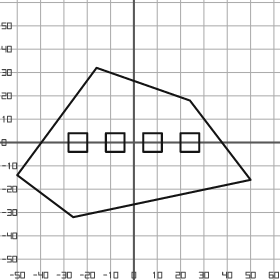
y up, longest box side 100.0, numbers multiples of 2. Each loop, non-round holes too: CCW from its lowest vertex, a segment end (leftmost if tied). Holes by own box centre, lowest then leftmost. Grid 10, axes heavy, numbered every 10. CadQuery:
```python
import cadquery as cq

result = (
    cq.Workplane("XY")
    .moveTo(-26.0, -32.0)
    .lineTo(50.0, -16.0)
    .lineTo(24.0, 18.0)
    .lineTo(-16.0, 32.0)
    .lineTo(-50.0, -14.0)
    .close()
    .moveTo(-28.0, -4.0)
    .lineTo(-20.0, -4.0)
    .lineTo(-20.0, 4.0)
    .lineTo(-28.0, 4.0)
    .close()
    .moveTo(-12.0, -4.0)
    .lineTo(-4.0, -4.0)
    .lineTo(-4.0, 4.0)
    .lineTo(-12.0, 4.0)
    .close()
    .moveTo(4.0, -4.0)
    .lineTo(12.0, -4.0)
    .lineTo(12.0, 4.0)
    .lineTo(4.0, 4.0)
    .close()
    .moveTo(20.0, -4.0)
    .lineTo(28.0, -4.0)
    .lineTo(28.0, 4.0)
    .lineTo(20.0, 4.0)
    .close()
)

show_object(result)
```